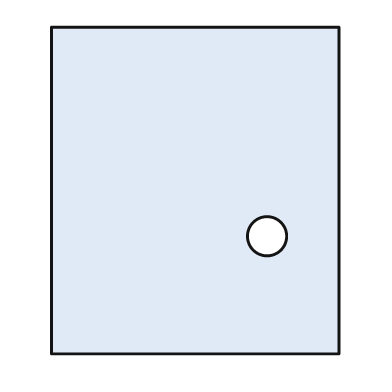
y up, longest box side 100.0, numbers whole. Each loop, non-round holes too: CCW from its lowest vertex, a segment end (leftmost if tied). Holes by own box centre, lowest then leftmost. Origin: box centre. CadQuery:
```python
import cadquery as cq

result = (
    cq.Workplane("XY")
    .moveTo(-44.0, -50.0)
    .lineTo(44.0, -50.0)
    .lineTo(44.0, 50.0)
    .lineTo(-44.0, 50.0)
    .close()
    .moveTo(22.0, -14.0)
    .circle(6.0)
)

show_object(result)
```